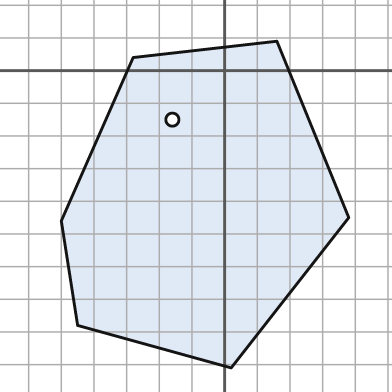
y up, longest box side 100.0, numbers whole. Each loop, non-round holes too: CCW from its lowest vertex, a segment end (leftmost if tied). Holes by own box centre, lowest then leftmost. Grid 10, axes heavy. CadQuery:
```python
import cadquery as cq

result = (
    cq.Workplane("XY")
    .moveTo(2.0, -91.0)
    .lineTo(38.0, -45.0)
    .lineTo(16.0, 9.0)
    .lineTo(-28.0, 4.0)
    .lineTo(-50.0, -46.0)
    .lineTo(-45.0, -78.0)
    .close()
    .moveTo(-16.0, -15.0)
    .circle(2.0)
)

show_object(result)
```